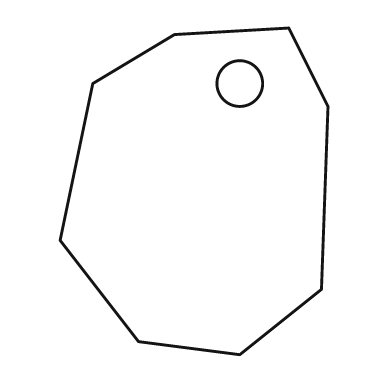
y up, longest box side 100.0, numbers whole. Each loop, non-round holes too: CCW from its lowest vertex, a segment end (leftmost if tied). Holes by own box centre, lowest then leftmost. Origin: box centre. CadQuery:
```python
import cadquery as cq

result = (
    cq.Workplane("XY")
    .moveTo(14.0, -50.0)
    .lineTo(39.0, -30.0)
    .lineTo(41.0, 26.0)
    .lineTo(29.0, 50.0)
    .lineTo(-6.0, 48.0)
    .lineTo(-31.0, 33.0)
    .lineTo(-41.0, -15.0)
    .lineTo(-17.0, -46.0)
    .close()
    .moveTo(14.0, 33.0)
    .circle(7.0)
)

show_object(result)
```